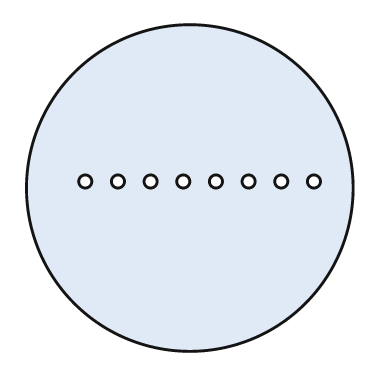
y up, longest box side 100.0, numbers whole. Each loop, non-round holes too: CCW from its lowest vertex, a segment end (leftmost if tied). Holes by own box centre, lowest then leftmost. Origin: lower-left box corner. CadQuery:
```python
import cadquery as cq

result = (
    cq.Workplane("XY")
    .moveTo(50.0, 50.0)
    .circle(50.0)
    .moveTo(18.0, 52.0)
    .circle(2.0)
    .moveTo(28.0, 52.0)
    .circle(2.0)
    .moveTo(38.0, 52.0)
    .circle(2.0)
    .moveTo(48.0, 52.0)
    .circle(2.0)
    .moveTo(58.0, 52.0)
    .circle(2.0)
    .moveTo(68.0, 52.0)
    .circle(2.0)
    .moveTo(78.0, 52.0)
    .circle(2.0)
    .moveTo(88.0, 52.0)
    .circle(2.0)
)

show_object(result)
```